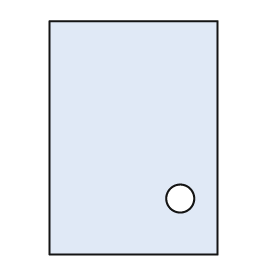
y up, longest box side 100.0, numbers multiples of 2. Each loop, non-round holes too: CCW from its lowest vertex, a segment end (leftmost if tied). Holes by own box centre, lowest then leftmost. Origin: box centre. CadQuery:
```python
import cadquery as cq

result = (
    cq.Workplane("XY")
    .moveTo(-36.0, -50.0)
    .lineTo(36.0, -50.0)
    .lineTo(36.0, 50.0)
    .lineTo(-36.0, 50.0)
    .close()
    .moveTo(20.0, -26.0)
    .circle(6.0)
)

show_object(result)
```